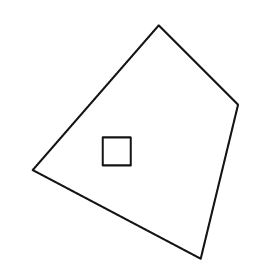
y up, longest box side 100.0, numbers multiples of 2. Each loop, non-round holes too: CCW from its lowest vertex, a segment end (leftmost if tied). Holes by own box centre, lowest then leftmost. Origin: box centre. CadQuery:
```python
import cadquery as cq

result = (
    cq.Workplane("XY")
    .moveTo(28.0, -50.0)
    .lineTo(44.0, 16.0)
    .lineTo(10.0, 50.0)
    .lineTo(-44.0, -12.0)
    .close()
    .moveTo(-14.0, -10.0)
    .lineTo(-2.0, -10.0)
    .lineTo(-2.0, 2.0)
    .lineTo(-14.0, 2.0)
    .close()
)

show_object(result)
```